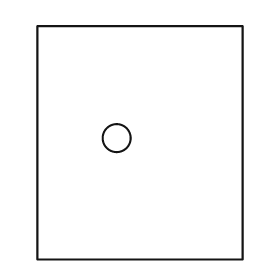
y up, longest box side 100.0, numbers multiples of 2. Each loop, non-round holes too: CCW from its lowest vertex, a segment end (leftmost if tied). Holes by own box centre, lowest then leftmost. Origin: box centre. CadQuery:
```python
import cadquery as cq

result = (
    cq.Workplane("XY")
    .moveTo(-44.0, -50.0)
    .lineTo(44.0, -50.0)
    .lineTo(44.0, 50.0)
    .lineTo(-44.0, 50.0)
    .close()
    .moveTo(-10.0, 2.0)
    .circle(6.0)
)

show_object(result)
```